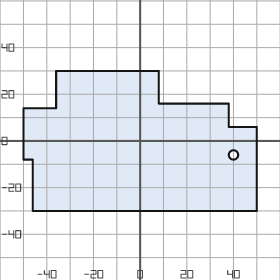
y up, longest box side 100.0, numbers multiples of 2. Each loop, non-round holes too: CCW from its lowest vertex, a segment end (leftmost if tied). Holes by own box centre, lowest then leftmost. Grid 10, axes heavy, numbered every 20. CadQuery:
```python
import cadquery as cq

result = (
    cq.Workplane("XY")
    .moveTo(-46.0, -30.0)
    .lineTo(50.0, -30.0)
    .lineTo(50.0, 6.0)
    .lineTo(38.0, 6.0)
    .lineTo(38.0, 16.0)
    .lineTo(8.0, 16.0)
    .lineTo(8.0, 30.0)
    .lineTo(-36.0, 30.0)
    .lineTo(-36.0, 14.0)
    .lineTo(-50.0, 14.0)
    .lineTo(-50.0, -8.0)
    .lineTo(-46.0, -8.0)
    .close()
    .moveTo(40.0, -6.0)
    .circle(2.0)
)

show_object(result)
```